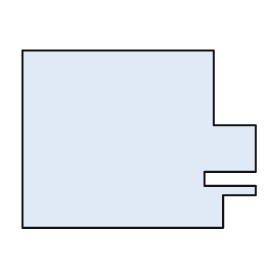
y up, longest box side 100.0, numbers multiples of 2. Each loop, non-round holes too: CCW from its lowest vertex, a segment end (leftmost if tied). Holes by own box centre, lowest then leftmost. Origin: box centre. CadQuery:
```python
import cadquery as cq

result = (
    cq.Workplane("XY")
    .moveTo(-50.0, -38.0)
    .lineTo(36.0, -38.0)
    .lineTo(36.0, -24.0)
    .lineTo(50.0, -24.0)
    .lineTo(50.0, -20.0)
    .lineTo(28.0, -20.0)
    .lineTo(28.0, -14.0)
    .lineTo(50.0, -14.0)
    .lineTo(50.0, 6.0)
    .lineTo(32.0, 6.0)
    .lineTo(32.0, 38.0)
    .lineTo(-50.0, 38.0)
    .close()
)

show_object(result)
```